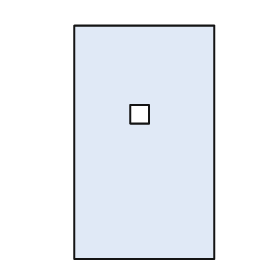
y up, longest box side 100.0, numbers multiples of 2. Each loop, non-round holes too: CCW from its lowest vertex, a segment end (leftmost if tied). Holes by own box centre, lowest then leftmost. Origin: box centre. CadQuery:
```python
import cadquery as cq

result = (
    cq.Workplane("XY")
    .moveTo(-30.0, -50.0)
    .lineTo(30.0, -50.0)
    .lineTo(30.0, 50.0)
    .lineTo(-30.0, 50.0)
    .close()
    .moveTo(-6.0, 8.0)
    .lineTo(2.0, 8.0)
    .lineTo(2.0, 16.0)
    .lineTo(-6.0, 16.0)
    .close()
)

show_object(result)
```